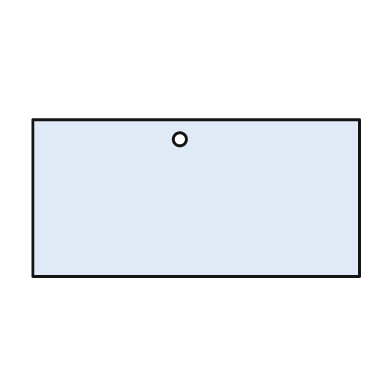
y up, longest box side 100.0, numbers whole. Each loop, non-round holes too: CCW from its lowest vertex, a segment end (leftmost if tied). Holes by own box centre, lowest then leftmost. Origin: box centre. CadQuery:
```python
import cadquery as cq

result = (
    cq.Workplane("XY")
    .moveTo(-50.0, -24.0)
    .lineTo(50.0, -24.0)
    .lineTo(50.0, 24.0)
    .lineTo(-50.0, 24.0)
    .close()
    .moveTo(-5.0, 18.0)
    .circle(2.0)
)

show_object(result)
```